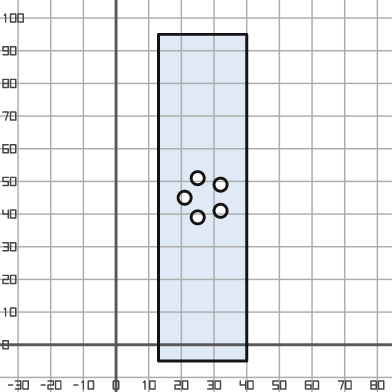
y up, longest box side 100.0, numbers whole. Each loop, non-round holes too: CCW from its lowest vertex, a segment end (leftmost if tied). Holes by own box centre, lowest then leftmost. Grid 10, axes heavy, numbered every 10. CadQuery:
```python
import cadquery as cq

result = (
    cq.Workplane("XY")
    .moveTo(13.0, -5.0)
    .lineTo(40.0, -5.0)
    .lineTo(40.0, 95.0)
    .lineTo(13.0, 95.0)
    .close()
    .moveTo(25.0, 39.0)
    .circle(2.0)
    .moveTo(32.0, 41.0)
    .circle(2.0)
    .moveTo(21.0, 45.0)
    .circle(2.0)
    .moveTo(32.0, 49.0)
    .circle(2.0)
    .moveTo(25.0, 51.0)
    .circle(2.0)
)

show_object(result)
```